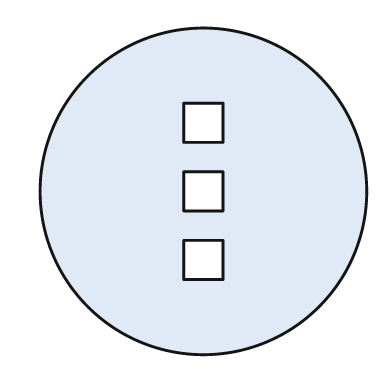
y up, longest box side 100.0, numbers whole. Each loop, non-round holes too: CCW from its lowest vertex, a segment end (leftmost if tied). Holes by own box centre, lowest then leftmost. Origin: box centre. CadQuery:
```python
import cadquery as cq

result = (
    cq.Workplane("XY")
    .moveTo(0.0, 0.0)
    .circle(50.0)
    .moveTo(-6.0, -27.0)
    .lineTo(6.0, -27.0)
    .lineTo(6.0, -15.0)
    .lineTo(-6.0, -15.0)
    .close()
    .moveTo(-6.0, -6.0)
    .lineTo(6.0, -6.0)
    .lineTo(6.0, 6.0)
    .lineTo(-6.0, 6.0)
    .close()
    .moveTo(-6.0, 15.0)
    .lineTo(6.0, 15.0)
    .lineTo(6.0, 27.0)
    .lineTo(-6.0, 27.0)
    .close()
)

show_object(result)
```